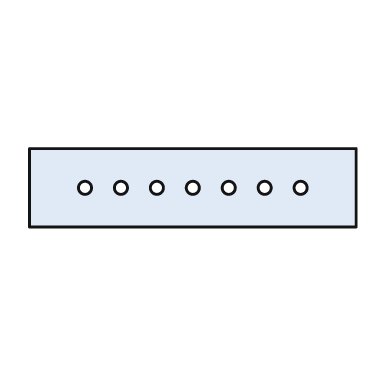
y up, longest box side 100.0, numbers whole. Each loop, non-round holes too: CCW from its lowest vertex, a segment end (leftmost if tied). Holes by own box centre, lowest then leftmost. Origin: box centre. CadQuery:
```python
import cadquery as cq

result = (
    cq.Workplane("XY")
    .moveTo(-50.0, -12.0)
    .lineTo(50.0, -12.0)
    .lineTo(50.0, 12.0)
    .lineTo(-50.0, 12.0)
    .close()
    .moveTo(-33.0, 0.0)
    .circle(2.0)
    .moveTo(-22.0, 0.0)
    .circle(2.0)
    .moveTo(-11.0, 0.0)
    .circle(2.0)
    .moveTo(0.0, 0.0)
    .circle(2.0)
    .moveTo(11.0, 0.0)
    .circle(2.0)
    .moveTo(22.0, 0.0)
    .circle(2.0)
    .moveTo(33.0, 0.0)
    .circle(2.0)
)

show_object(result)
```